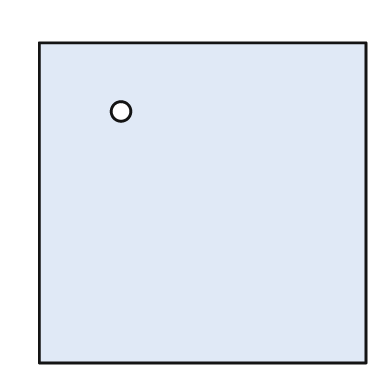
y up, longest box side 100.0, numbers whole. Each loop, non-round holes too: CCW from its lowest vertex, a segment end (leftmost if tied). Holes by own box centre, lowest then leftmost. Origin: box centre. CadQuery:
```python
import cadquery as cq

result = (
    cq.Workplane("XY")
    .moveTo(-50.0, -49.0)
    .lineTo(50.0, -49.0)
    .lineTo(50.0, 49.0)
    .lineTo(-50.0, 49.0)
    .close()
    .moveTo(-25.0, 28.0)
    .circle(3.0)
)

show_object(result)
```